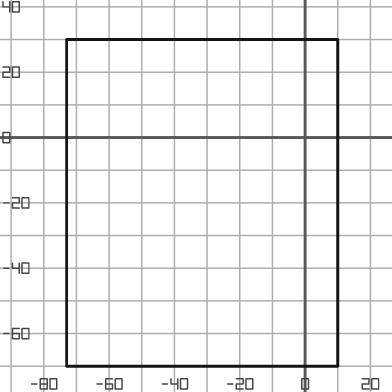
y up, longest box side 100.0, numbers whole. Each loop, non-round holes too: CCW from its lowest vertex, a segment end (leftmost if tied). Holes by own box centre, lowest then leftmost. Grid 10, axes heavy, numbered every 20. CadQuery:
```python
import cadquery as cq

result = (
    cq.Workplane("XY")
    .moveTo(-73.0, -70.0)
    .lineTo(10.0, -70.0)
    .lineTo(10.0, 30.0)
    .lineTo(-73.0, 30.0)
    .close()
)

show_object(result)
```